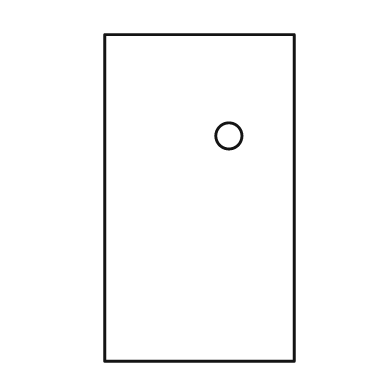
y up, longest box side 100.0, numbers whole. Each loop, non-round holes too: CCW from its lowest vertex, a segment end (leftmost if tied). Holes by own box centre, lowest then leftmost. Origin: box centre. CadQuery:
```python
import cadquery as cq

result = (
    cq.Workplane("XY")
    .moveTo(-29.0, -50.0)
    .lineTo(29.0, -50.0)
    .lineTo(29.0, 50.0)
    .lineTo(-29.0, 50.0)
    .close()
    .moveTo(9.0, 19.0)
    .circle(4.0)
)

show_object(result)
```